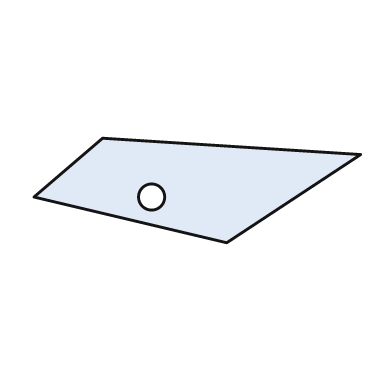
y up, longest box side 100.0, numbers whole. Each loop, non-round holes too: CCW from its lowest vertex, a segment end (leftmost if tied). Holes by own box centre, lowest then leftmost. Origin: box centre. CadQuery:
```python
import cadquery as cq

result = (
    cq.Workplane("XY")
    .moveTo(9.0, -16.0)
    .lineTo(50.0, 11.0)
    .lineTo(-29.0, 16.0)
    .lineTo(-50.0, -2.0)
    .close()
    .moveTo(-14.0, -2.0)
    .circle(4.0)
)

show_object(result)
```